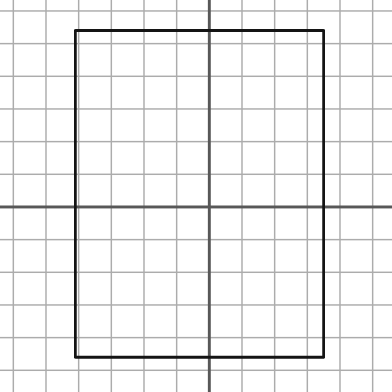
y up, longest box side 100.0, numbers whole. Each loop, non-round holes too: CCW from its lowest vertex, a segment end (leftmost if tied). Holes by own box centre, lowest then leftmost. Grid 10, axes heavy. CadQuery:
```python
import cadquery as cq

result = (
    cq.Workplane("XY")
    .moveTo(-41.0, -46.0)
    .lineTo(35.0, -46.0)
    .lineTo(35.0, 54.0)
    .lineTo(-41.0, 54.0)
    .close()
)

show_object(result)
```